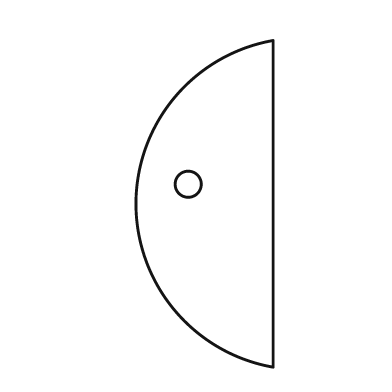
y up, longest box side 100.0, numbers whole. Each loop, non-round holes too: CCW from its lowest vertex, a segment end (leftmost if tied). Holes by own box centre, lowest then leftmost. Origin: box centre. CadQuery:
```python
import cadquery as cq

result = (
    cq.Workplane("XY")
    .moveTo(21.0, -50.0)
    .lineTo(21.0, 50.0)
    .threePointArc((-21.0, 0.0), (21.0, -50.0))
    .close()
    .moveTo(-5.0, 6.0)
    .circle(4.0)
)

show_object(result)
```